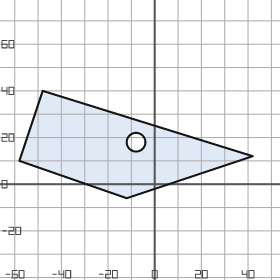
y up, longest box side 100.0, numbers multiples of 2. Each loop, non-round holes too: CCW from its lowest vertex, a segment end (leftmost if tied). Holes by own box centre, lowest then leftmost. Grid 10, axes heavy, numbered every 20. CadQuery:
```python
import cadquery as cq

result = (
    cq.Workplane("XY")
    .moveTo(-12.0, -6.0)
    .lineTo(42.0, 12.0)
    .lineTo(-48.0, 40.0)
    .lineTo(-58.0, 10.0)
    .close()
    .moveTo(-8.0, 18.0)
    .circle(4.0)
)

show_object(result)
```